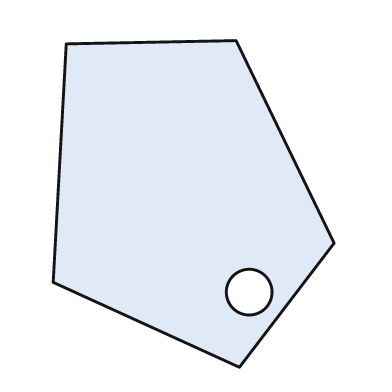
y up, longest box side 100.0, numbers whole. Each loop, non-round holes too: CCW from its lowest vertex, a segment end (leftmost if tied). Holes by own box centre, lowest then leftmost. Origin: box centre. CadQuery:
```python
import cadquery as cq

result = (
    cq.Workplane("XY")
    .moveTo(14.0, -50.0)
    .lineTo(43.0, -12.0)
    .lineTo(13.0, 50.0)
    .lineTo(-39.0, 49.0)
    .lineTo(-43.0, -24.0)
    .close()
    .moveTo(17.0, -27.0)
    .circle(7.0)
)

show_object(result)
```